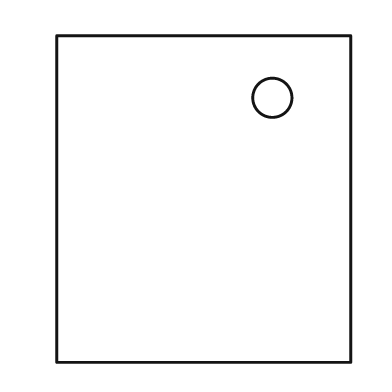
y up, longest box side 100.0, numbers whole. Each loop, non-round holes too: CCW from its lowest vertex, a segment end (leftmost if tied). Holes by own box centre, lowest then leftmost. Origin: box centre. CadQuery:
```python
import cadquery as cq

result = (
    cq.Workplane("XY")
    .moveTo(-45.0, -50.0)
    .lineTo(45.0, -50.0)
    .lineTo(45.0, 50.0)
    .lineTo(-45.0, 50.0)
    .close()
    .moveTo(21.0, 31.0)
    .circle(6.0)
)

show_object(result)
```